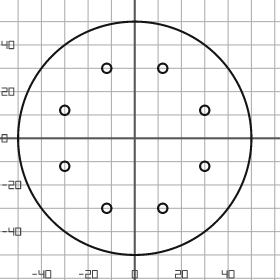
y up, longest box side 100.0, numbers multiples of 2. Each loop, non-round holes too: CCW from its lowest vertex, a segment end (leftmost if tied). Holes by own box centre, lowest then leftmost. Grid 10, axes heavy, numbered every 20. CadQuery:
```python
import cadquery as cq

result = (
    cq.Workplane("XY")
    .moveTo(0.0, 0.0)
    .circle(50.0)
    .moveTo(-12.0, -30.0)
    .circle(2.0)
    .moveTo(12.0, -30.0)
    .circle(2.0)
    .moveTo(-30.0, -12.0)
    .circle(2.0)
    .moveTo(30.0, -12.0)
    .circle(2.0)
    .moveTo(-30.0, 12.0)
    .circle(2.0)
    .moveTo(30.0, 12.0)
    .circle(2.0)
    .moveTo(-12.0, 30.0)
    .circle(2.0)
    .moveTo(12.0, 30.0)
    .circle(2.0)
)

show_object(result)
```